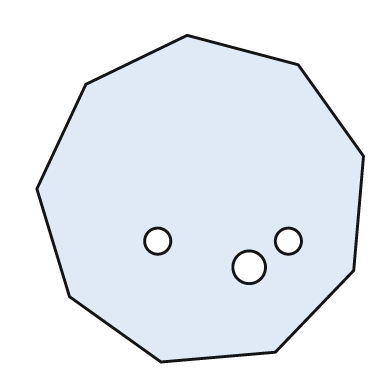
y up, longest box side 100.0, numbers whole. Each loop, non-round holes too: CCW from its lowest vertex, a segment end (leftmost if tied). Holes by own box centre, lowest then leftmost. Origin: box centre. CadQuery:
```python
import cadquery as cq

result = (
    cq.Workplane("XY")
    .moveTo(-12.0, -50.0)
    .lineTo(23.0, -47.0)
    .lineTo(47.0, -22.0)
    .lineTo(50.0, 13.0)
    .lineTo(30.0, 41.0)
    .lineTo(-4.0, 50.0)
    .lineTo(-35.0, 35.0)
    .lineTo(-50.0, 3.0)
    .lineTo(-40.0, -30.0)
    .close()
    .moveTo(15.0, -21.0)
    .circle(5.0)
    .moveTo(-13.0, -13.0)
    .circle(4.0)
    .moveTo(27.0, -13.0)
    .circle(4.0)
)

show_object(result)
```